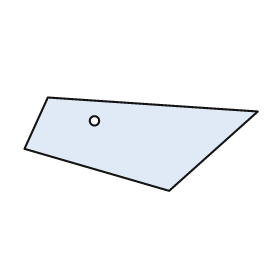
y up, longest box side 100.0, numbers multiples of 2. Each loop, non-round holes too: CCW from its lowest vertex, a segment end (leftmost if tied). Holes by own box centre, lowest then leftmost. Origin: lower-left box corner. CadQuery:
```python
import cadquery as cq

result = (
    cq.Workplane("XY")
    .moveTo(62.0, 0.0)
    .lineTo(100.0, 34.0)
    .lineTo(10.0, 40.0)
    .lineTo(0.0, 18.0)
    .close()
    .moveTo(30.0, 30.0)
    .circle(2.0)
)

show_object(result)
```